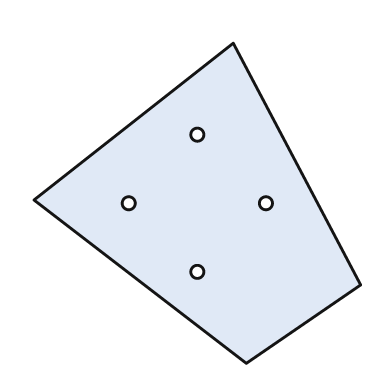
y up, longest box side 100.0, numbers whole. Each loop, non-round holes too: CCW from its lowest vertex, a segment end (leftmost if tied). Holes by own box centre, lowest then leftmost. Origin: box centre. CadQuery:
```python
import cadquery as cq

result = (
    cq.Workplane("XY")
    .moveTo(15.0, -49.0)
    .lineTo(50.0, -25.0)
    .lineTo(11.0, 49.0)
    .lineTo(-50.0, 1.0)
    .close()
    .moveTo(0.0, -21.0)
    .circle(2.0)
    .moveTo(-21.0, 0.0)
    .circle(2.0)
    .moveTo(21.0, 0.0)
    .circle(2.0)
    .moveTo(0.0, 21.0)
    .circle(2.0)
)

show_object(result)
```